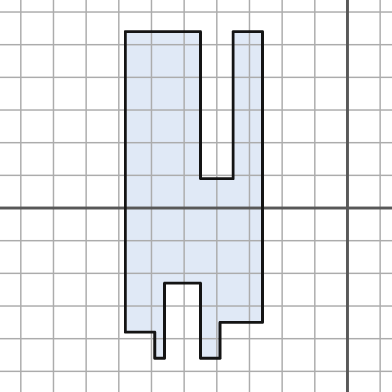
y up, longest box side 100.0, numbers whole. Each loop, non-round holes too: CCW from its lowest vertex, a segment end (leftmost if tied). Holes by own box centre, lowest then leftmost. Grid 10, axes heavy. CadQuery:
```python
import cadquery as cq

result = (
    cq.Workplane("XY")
    .moveTo(-59.0, -46.0)
    .lineTo(-56.0, -46.0)
    .lineTo(-56.0, -23.0)
    .lineTo(-45.0, -23.0)
    .lineTo(-45.0, -46.0)
    .lineTo(-39.0, -46.0)
    .lineTo(-39.0, -35.0)
    .lineTo(-26.0, -35.0)
    .lineTo(-26.0, 54.0)
    .lineTo(-35.0, 54.0)
    .lineTo(-35.0, 9.0)
    .lineTo(-45.0, 9.0)
    .lineTo(-45.0, 54.0)
    .lineTo(-68.0, 54.0)
    .lineTo(-68.0, -38.0)
    .lineTo(-59.0, -38.0)
    .close()
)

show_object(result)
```